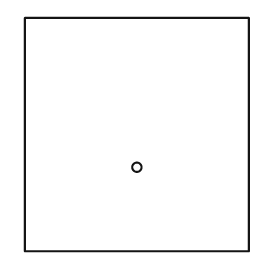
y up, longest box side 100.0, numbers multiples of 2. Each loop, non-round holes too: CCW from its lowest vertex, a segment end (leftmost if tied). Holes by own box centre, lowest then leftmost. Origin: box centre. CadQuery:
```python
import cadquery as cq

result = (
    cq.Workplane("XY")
    .moveTo(-48.0, -50.0)
    .lineTo(48.0, -50.0)
    .lineTo(48.0, 50.0)
    .lineTo(-48.0, 50.0)
    .close()
    .moveTo(0.0, -14.0)
    .circle(2.0)
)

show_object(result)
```